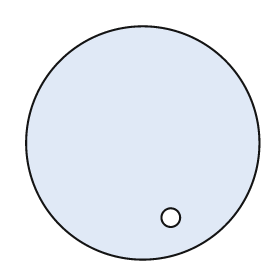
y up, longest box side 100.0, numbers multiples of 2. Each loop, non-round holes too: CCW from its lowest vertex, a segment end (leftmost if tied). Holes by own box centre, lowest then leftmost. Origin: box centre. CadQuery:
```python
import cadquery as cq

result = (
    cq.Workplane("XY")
    .moveTo(0.0, 0.0)
    .circle(50.0)
    .moveTo(12.0, -32.0)
    .circle(4.0)
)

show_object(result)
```